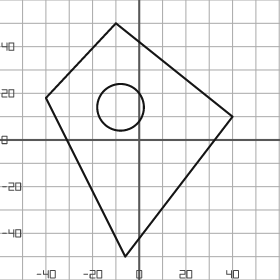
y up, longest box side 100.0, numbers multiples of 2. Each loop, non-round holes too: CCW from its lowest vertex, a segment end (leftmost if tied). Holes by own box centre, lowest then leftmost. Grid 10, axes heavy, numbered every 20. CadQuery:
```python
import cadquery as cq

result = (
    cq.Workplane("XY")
    .moveTo(-6.0, -50.0)
    .lineTo(40.0, 10.0)
    .lineTo(-10.0, 50.0)
    .lineTo(-40.0, 18.0)
    .close()
    .moveTo(-8.0, 14.0)
    .circle(10.0)
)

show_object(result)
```